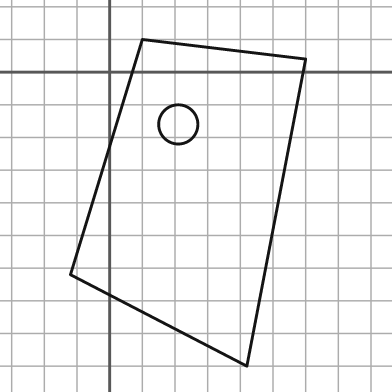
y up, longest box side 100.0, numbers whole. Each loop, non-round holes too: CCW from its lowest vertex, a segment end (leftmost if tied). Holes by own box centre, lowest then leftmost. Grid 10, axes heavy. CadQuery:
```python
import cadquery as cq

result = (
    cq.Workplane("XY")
    .moveTo(42.0, -90.0)
    .lineTo(60.0, 4.0)
    .lineTo(10.0, 10.0)
    .lineTo(-12.0, -62.0)
    .close()
    .moveTo(21.0, -16.0)
    .circle(6.0)
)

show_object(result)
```